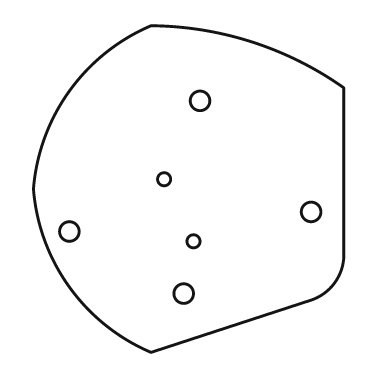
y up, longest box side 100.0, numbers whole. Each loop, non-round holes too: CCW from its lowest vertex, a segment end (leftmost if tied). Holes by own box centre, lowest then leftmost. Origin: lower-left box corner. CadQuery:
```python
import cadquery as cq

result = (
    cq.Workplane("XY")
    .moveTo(36.0, 0.0)
    .lineTo(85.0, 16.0)
    .threePointArc((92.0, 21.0), (95.0, 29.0))
    .lineTo(95.0, 81.0)
    .threePointArc((67.0, 95.0), (36.0, 100.0))
    .threePointArc((11.0, 80.0), (0.0, 50.0))
    .threePointArc((11.0, 20.0), (36.0, 0.0))
    .close()
    .moveTo(46.0, 18.0)
    .circle(3.0)
    .moveTo(49.0, 34.0)
    .circle(2.0)
    .moveTo(11.0, 37.0)
    .circle(3.0)
    .moveTo(85.0, 43.0)
    .circle(3.0)
    .moveTo(40.0, 53.0)
    .circle(2.0)
    .moveTo(51.0, 77.0)
    .circle(3.0)
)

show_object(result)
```